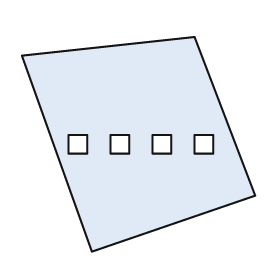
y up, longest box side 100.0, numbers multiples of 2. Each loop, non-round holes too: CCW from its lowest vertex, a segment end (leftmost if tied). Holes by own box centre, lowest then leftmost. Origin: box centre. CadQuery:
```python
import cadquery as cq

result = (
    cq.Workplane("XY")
    .moveTo(-20.0, -46.0)
    .lineTo(50.0, -22.0)
    .lineTo(24.0, 46.0)
    .lineTo(-50.0, 38.0)
    .close()
    .moveTo(-30.0, -4.0)
    .lineTo(-22.0, -4.0)
    .lineTo(-22.0, 4.0)
    .lineTo(-30.0, 4.0)
    .close()
    .moveTo(-12.0, -4.0)
    .lineTo(-4.0, -4.0)
    .lineTo(-4.0, 4.0)
    .lineTo(-12.0, 4.0)
    .close()
    .moveTo(6.0, -4.0)
    .lineTo(14.0, -4.0)
    .lineTo(14.0, 4.0)
    .lineTo(6.0, 4.0)
    .close()
    .moveTo(24.0, -4.0)
    .lineTo(32.0, -4.0)
    .lineTo(32.0, 4.0)
    .lineTo(24.0, 4.0)
    .close()
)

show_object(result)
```